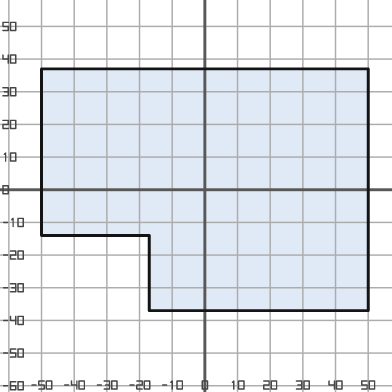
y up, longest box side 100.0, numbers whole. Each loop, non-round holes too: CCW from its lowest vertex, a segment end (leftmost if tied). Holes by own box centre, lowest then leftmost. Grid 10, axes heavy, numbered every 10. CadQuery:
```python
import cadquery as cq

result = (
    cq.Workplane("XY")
    .moveTo(-17.0, -37.0)
    .lineTo(50.0, -37.0)
    .lineTo(50.0, 37.0)
    .lineTo(-50.0, 37.0)
    .lineTo(-50.0, -14.0)
    .lineTo(-17.0, -14.0)
    .close()
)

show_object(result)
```